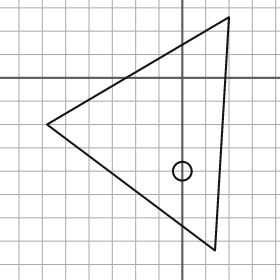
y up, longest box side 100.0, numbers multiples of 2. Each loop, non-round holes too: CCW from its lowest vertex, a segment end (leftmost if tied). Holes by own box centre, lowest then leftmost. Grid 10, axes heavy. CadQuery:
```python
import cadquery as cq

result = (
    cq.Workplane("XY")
    .moveTo(14.0, -74.0)
    .lineTo(20.0, 26.0)
    .lineTo(-58.0, -20.0)
    .close()
    .moveTo(0.0, -40.0)
    .circle(4.0)
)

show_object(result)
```